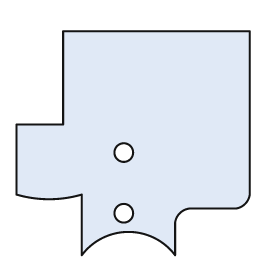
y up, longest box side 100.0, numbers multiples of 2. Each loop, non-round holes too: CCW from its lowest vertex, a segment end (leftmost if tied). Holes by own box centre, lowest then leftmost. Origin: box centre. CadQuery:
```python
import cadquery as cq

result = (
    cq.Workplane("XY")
    .moveTo(-22.0, -48.0)
    .threePointArc((-2.0, -38.0), (18.0, -48.0))
    .lineTo(18.0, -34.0)
    .threePointArc((20.0, -30.0), (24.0, -28.0))
    .lineTo(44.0, -28.0)
    .threePointArc((48.0, -26.0), (50.0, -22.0))
    .lineTo(50.0, 48.0)
    .lineTo(-30.0, 48.0)
    .lineTo(-30.0, 8.0)
    .lineTo(-50.0, 8.0)
    .lineTo(-50.0, -22.0)
    .threePointArc((-36.0, -24.0), (-22.0, -22.0))
    .close()
    .moveTo(-4.0, -30.0)
    .circle(4.0)
    .moveTo(-4.0, -4.0)
    .circle(4.0)
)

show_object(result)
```